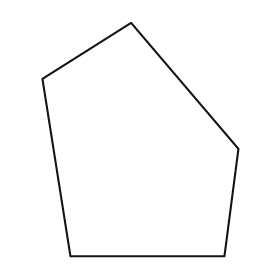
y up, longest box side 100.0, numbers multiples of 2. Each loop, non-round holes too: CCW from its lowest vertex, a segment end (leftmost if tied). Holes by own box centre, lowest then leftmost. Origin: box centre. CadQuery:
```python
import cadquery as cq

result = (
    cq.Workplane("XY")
    .moveTo(-30.0, -50.0)
    .lineTo(36.0, -50.0)
    .lineTo(42.0, -4.0)
    .lineTo(-4.0, 50.0)
    .lineTo(-42.0, 26.0)
    .close()
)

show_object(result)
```